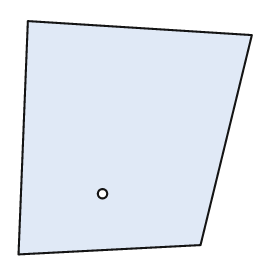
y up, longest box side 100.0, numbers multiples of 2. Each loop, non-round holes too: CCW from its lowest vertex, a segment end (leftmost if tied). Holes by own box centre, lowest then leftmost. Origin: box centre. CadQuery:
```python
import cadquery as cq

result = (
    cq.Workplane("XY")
    .moveTo(-50.0, -50.0)
    .lineTo(28.0, -46.0)
    .lineTo(50.0, 44.0)
    .lineTo(-46.0, 50.0)
    .close()
    .moveTo(-14.0, -24.0)
    .circle(2.0)
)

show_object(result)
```